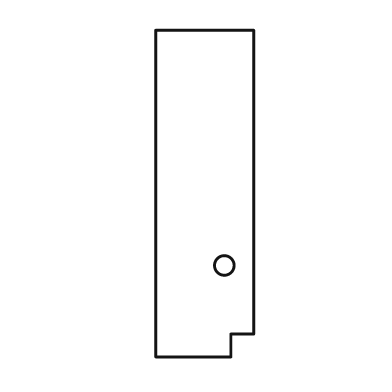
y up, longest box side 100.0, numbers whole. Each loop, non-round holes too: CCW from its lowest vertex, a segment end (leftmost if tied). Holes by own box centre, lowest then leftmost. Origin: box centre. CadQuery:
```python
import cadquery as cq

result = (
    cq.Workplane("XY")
    .moveTo(-15.0, -50.0)
    .lineTo(8.0, -50.0)
    .lineTo(8.0, -43.0)
    .lineTo(15.0, -43.0)
    .lineTo(15.0, 50.0)
    .lineTo(-15.0, 50.0)
    .close()
    .moveTo(6.0, -22.0)
    .circle(3.0)
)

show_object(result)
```